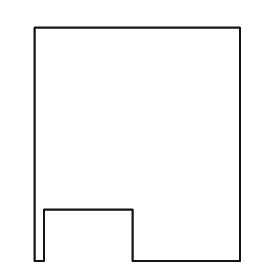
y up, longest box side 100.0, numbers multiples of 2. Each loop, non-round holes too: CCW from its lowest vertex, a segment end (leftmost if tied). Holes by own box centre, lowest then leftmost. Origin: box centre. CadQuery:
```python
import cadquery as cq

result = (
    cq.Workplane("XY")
    .moveTo(-44.0, -50.0)
    .lineTo(-40.0, -50.0)
    .lineTo(-40.0, -28.0)
    .lineTo(-2.0, -28.0)
    .lineTo(-2.0, -50.0)
    .lineTo(44.0, -50.0)
    .lineTo(44.0, 50.0)
    .lineTo(-44.0, 50.0)
    .close()
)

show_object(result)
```